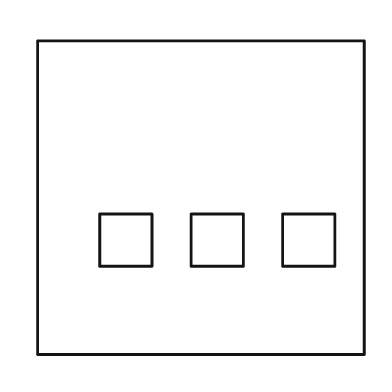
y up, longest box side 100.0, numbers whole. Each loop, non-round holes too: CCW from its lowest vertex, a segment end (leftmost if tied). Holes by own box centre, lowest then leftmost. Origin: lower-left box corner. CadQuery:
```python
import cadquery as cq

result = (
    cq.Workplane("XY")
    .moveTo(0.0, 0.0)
    .lineTo(100.0, 0.0)
    .lineTo(100.0, 96.0)
    .lineTo(0.0, 96.0)
    .close()
    .moveTo(19.0, 27.0)
    .lineTo(35.0, 27.0)
    .lineTo(35.0, 43.0)
    .lineTo(19.0, 43.0)
    .close()
    .moveTo(47.0, 27.0)
    .lineTo(63.0, 27.0)
    .lineTo(63.0, 43.0)
    .lineTo(47.0, 43.0)
    .close()
    .moveTo(75.0, 27.0)
    .lineTo(91.0, 27.0)
    .lineTo(91.0, 43.0)
    .lineTo(75.0, 43.0)
    .close()
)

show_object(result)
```